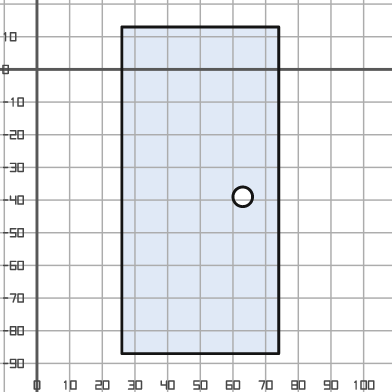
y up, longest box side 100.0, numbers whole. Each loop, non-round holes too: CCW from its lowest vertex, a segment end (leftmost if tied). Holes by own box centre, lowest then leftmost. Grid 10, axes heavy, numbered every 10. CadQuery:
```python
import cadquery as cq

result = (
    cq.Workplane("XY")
    .moveTo(26.0, -87.0)
    .lineTo(74.0, -87.0)
    .lineTo(74.0, 13.0)
    .lineTo(26.0, 13.0)
    .close()
    .moveTo(63.0, -39.0)
    .circle(3.0)
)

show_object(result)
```